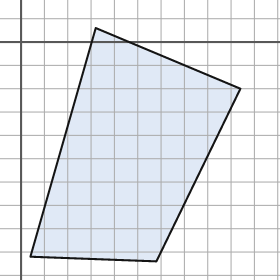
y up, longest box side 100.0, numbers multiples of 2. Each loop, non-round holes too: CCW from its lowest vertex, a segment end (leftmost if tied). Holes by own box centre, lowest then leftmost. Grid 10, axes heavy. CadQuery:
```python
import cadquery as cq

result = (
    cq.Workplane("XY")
    .moveTo(58.0, -94.0)
    .lineTo(94.0, -20.0)
    .lineTo(32.0, 6.0)
    .lineTo(4.0, -92.0)
    .close()
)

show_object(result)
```